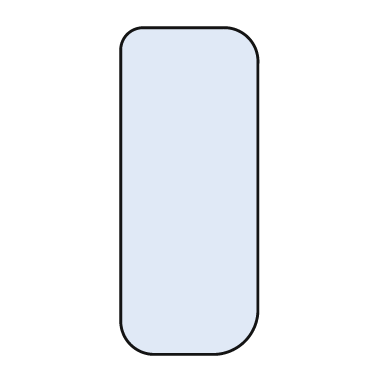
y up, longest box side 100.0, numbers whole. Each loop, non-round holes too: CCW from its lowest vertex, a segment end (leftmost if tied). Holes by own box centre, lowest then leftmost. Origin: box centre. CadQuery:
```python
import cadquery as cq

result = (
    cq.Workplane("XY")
    .moveTo(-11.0, -50.0)
    .lineTo(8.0, -50.0)
    .threePointArc((17.0, -46.0), (21.0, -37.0))
    .lineTo(21.0, 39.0)
    .threePointArc((18.0, 47.0), (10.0, 50.0))
    .lineTo(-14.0, 50.0)
    .threePointArc((-19.0, 48.0), (-21.0, 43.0))
    .lineTo(-21.0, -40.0)
    .threePointArc((-18.0, -47.0), (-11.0, -50.0))
    .close()
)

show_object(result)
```